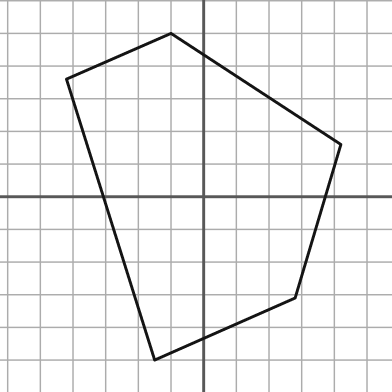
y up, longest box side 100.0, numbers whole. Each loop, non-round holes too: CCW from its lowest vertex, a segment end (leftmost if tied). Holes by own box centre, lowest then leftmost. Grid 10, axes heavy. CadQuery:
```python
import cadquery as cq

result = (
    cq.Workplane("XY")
    .moveTo(-15.0, -50.0)
    .lineTo(28.0, -31.0)
    .lineTo(42.0, 16.0)
    .lineTo(-10.0, 50.0)
    .lineTo(-42.0, 36.0)
    .close()
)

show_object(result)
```